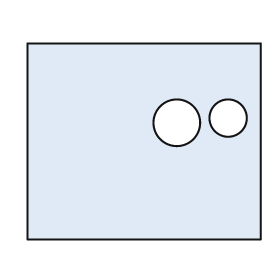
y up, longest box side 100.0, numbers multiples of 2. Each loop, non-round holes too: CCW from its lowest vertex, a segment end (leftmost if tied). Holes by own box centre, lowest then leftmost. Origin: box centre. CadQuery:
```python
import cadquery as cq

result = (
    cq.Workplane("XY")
    .moveTo(-50.0, -42.0)
    .lineTo(50.0, -42.0)
    .lineTo(50.0, 42.0)
    .lineTo(-50.0, 42.0)
    .close()
    .moveTo(14.0, 8.0)
    .circle(10.0)
    .moveTo(36.0, 10.0)
    .circle(8.0)
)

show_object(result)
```